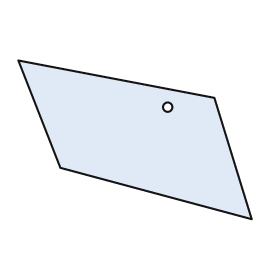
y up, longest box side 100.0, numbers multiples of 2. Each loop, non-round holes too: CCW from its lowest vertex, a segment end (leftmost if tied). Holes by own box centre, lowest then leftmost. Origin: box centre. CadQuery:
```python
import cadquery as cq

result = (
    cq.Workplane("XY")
    .moveTo(50.0, -34.0)
    .lineTo(34.0, 18.0)
    .lineTo(-50.0, 34.0)
    .lineTo(-32.0, -12.0)
    .close()
    .moveTo(14.0, 14.0)
    .circle(2.0)
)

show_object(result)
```